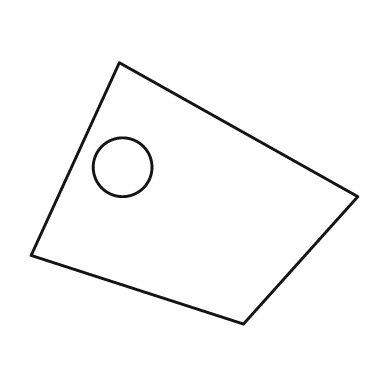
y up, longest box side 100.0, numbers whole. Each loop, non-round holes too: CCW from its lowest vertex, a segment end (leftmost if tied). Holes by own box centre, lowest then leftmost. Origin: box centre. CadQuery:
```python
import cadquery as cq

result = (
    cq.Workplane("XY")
    .moveTo(15.0, -40.0)
    .lineTo(50.0, -1.0)
    .lineTo(-23.0, 40.0)
    .lineTo(-50.0, -19.0)
    .close()
    .moveTo(-22.0, 8.0)
    .circle(9.0)
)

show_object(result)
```